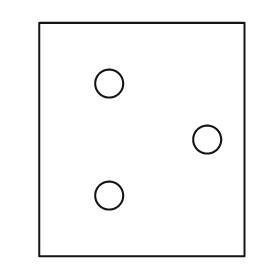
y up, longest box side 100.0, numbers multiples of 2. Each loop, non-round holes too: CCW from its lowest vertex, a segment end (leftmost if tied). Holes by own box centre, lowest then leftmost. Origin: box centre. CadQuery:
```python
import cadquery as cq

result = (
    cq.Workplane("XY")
    .moveTo(-44.0, -50.0)
    .lineTo(44.0, -50.0)
    .lineTo(44.0, 50.0)
    .lineTo(-44.0, 50.0)
    .close()
    .moveTo(-14.0, -24.0)
    .circle(6.0)
    .moveTo(28.0, 0.0)
    .circle(6.0)
    .moveTo(-14.0, 24.0)
    .circle(6.0)
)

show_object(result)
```